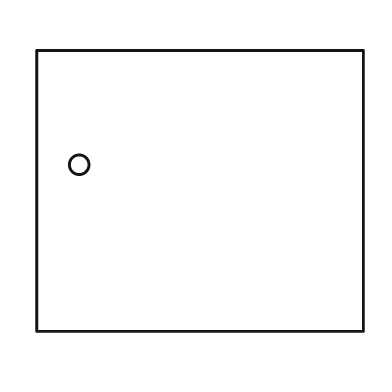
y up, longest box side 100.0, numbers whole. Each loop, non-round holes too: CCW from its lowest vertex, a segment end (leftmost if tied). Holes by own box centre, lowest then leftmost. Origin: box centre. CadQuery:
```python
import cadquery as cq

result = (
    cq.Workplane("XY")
    .moveTo(-50.0, -43.0)
    .lineTo(50.0, -43.0)
    .lineTo(50.0, 43.0)
    .lineTo(-50.0, 43.0)
    .close()
    .moveTo(-37.0, 8.0)
    .circle(3.0)
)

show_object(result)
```